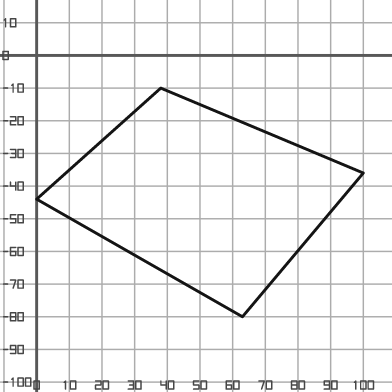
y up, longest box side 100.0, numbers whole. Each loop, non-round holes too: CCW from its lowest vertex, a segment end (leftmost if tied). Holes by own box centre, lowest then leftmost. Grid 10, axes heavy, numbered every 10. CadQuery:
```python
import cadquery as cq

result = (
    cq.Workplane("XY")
    .moveTo(63.0, -80.0)
    .lineTo(100.0, -36.0)
    .lineTo(38.0, -10.0)
    .lineTo(0.0, -44.0)
    .close()
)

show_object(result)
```